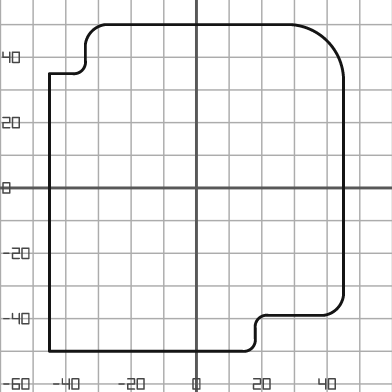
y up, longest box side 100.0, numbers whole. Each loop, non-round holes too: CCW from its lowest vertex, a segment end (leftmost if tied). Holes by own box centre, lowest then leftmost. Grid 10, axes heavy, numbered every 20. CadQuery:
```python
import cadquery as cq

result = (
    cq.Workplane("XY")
    .moveTo(-45.0, -50.0)
    .lineTo(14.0, -50.0)
    .threePointArc((17.0, -49.0), (18.0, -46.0))
    .lineTo(18.0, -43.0)
    .threePointArc((19.0, -40.0), (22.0, -39.0))
    .lineTo(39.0, -39.0)
    .threePointArc((43.0, -37.0), (45.0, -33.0))
    .lineTo(45.0, 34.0)
    .threePointArc((40.0, 45.0), (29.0, 50.0))
    .lineTo(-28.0, 50.0)
    .threePointArc((-32.0, 48.0), (-34.0, 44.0))
    .lineTo(-34.0, 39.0)
    .threePointArc((-35.0, 36.0), (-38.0, 35.0))
    .lineTo(-45.0, 35.0)
    .close()
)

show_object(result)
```